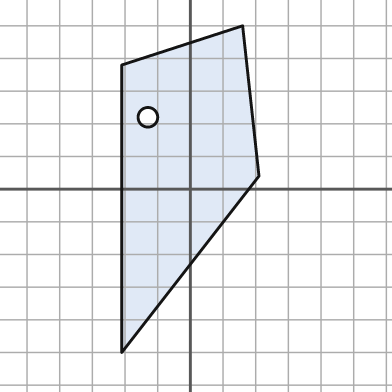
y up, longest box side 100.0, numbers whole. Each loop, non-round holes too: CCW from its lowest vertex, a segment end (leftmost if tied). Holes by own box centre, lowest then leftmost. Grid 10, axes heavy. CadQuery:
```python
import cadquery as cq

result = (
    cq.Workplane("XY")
    .moveTo(-21.0, -50.0)
    .lineTo(21.0, 4.0)
    .lineTo(16.0, 50.0)
    .lineTo(-21.0, 38.0)
    .close()
    .moveTo(-13.0, 22.0)
    .circle(3.0)
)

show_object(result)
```